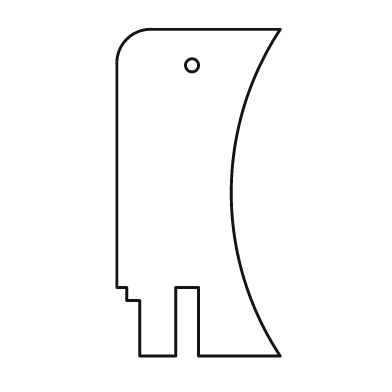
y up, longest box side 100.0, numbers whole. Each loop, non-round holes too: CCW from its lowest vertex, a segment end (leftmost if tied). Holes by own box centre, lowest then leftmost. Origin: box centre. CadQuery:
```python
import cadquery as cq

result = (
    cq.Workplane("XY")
    .moveTo(-18.0, -50.0)
    .lineTo(-7.0, -50.0)
    .lineTo(-7.0, -29.0)
    .lineTo(0.0, -29.0)
    .lineTo(0.0, -50.0)
    .lineTo(25.0, -50.0)
    .threePointArc((10.0, 0.0), (25.0, 50.0))
    .lineTo(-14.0, 50.0)
    .threePointArc((-22.0, 47.0), (-25.0, 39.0))
    .lineTo(-25.0, -29.0)
    .lineTo(-22.0, -29.0)
    .lineTo(-22.0, -33.0)
    .lineTo(-18.0, -33.0)
    .close()
    .moveTo(-2.0, 39.0)
    .circle(2.0)
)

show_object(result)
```